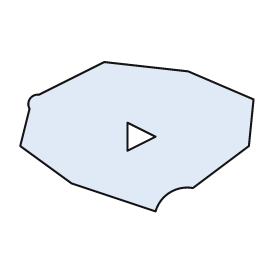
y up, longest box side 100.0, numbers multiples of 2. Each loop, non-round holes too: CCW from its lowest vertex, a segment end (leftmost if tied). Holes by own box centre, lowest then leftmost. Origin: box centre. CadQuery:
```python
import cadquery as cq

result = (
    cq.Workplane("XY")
    .moveTo(8.0, -32.0)
    .threePointArc((14.0, -24.0), (24.0, -22.0))
    .lineTo(48.0, -4.0)
    .lineTo(50.0, 16.0)
    .lineTo(22.0, 28.0)
    .lineTo(-14.0, 32.0)
    .lineTo(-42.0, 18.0)
    .threePointArc((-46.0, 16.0), (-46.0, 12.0))
    .lineTo(-50.0, -4.0)
    .lineTo(-28.0, -20.0)
    .close()
    .moveTo(-4.0, -6.0)
    .lineTo(8.0, 0.0)
    .lineTo(-4.0, 6.0)
    .close()
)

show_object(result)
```